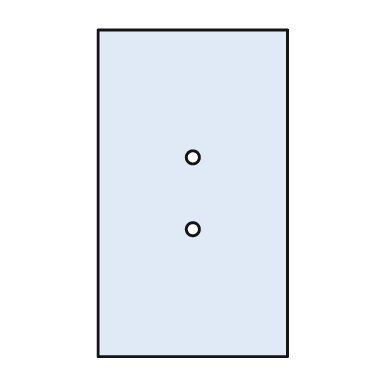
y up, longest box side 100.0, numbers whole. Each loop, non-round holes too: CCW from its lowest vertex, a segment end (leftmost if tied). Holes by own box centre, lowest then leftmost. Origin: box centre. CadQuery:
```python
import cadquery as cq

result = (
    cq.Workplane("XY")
    .moveTo(-29.0, -50.0)
    .lineTo(29.0, -50.0)
    .lineTo(29.0, 50.0)
    .lineTo(-29.0, 50.0)
    .close()
    .moveTo(0.0, -11.0)
    .circle(2.0)
    .moveTo(0.0, 11.0)
    .circle(2.0)
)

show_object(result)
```